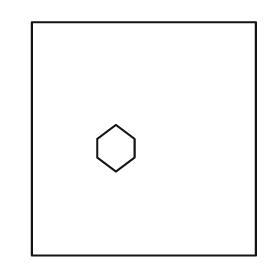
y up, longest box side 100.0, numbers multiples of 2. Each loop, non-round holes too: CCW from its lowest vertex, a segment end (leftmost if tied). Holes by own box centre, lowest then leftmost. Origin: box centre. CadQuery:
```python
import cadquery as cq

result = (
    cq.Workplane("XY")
    .moveTo(-48.0, -50.0)
    .lineTo(48.0, -50.0)
    .lineTo(48.0, 50.0)
    .lineTo(-48.0, 50.0)
    .close()
    .moveTo(-12.0, -14.0)
    .lineTo(-4.0, -8.0)
    .lineTo(-4.0, 0.0)
    .lineTo(-12.0, 6.0)
    .lineTo(-20.0, 0.0)
    .lineTo(-20.0, -8.0)
    .close()
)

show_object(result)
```